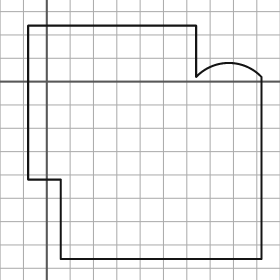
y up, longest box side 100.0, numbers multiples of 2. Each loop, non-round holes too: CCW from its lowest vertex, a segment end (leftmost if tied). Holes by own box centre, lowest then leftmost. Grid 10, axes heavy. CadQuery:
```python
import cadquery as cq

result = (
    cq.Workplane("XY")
    .moveTo(6.0, -76.0)
    .lineTo(92.0, -76.0)
    .lineTo(92.0, 2.0)
    .threePointArc((78.0, 8.0), (64.0, 2.0))
    .lineTo(64.0, 24.0)
    .lineTo(-8.0, 24.0)
    .lineTo(-8.0, -42.0)
    .lineTo(6.0, -42.0)
    .close()
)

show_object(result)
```